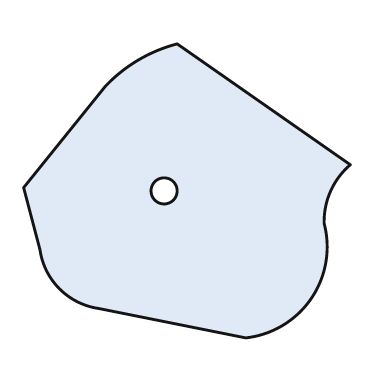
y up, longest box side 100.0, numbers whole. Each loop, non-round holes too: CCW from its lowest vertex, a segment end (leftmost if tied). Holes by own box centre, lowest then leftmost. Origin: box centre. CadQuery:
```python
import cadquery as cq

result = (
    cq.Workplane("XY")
    .moveTo(18.0, -45.0)
    .threePointArc((38.0, -33.0), (42.0, -10.0))
    .threePointArc((44.0, 0.0), (50.0, 8.0))
    .lineTo(-3.0, 45.0)
    .threePointArc((-15.0, 40.0), (-25.0, 32.0))
    .lineTo(-50.0, 1.0)
    .lineTo(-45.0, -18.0)
    .threePointArc((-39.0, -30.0), (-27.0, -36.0))
    .close()
    .moveTo(-7.0, 0.0)
    .circle(4.0)
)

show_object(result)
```